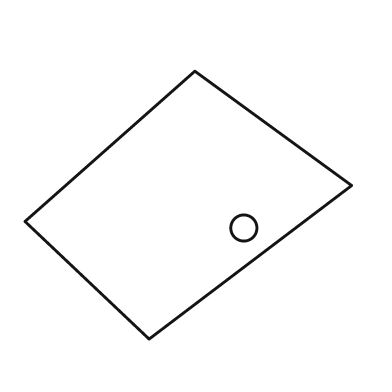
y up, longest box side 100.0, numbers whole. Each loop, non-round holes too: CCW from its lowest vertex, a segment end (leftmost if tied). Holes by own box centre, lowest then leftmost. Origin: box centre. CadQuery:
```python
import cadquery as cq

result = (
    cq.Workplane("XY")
    .moveTo(-12.0, -41.0)
    .lineTo(50.0, 6.0)
    .lineTo(2.0, 41.0)
    .lineTo(-50.0, -5.0)
    .close()
    .moveTo(17.0, -7.0)
    .circle(4.0)
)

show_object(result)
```